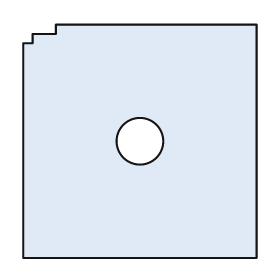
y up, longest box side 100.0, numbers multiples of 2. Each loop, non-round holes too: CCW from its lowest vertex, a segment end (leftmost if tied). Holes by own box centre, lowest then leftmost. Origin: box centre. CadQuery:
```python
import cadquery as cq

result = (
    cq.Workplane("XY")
    .moveTo(-50.0, -50.0)
    .lineTo(50.0, -50.0)
    .lineTo(50.0, 50.0)
    .lineTo(-36.0, 50.0)
    .lineTo(-36.0, 46.0)
    .lineTo(-46.0, 46.0)
    .lineTo(-46.0, 42.0)
    .lineTo(-50.0, 42.0)
    .close()
    .moveTo(0.0, 0.0)
    .circle(10.0)
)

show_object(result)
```